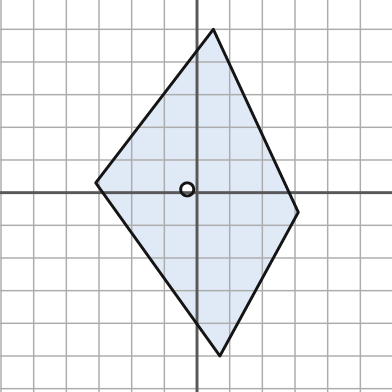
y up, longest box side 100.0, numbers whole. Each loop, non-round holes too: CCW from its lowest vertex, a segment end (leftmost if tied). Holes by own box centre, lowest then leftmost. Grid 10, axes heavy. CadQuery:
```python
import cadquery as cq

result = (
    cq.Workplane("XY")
    .moveTo(7.0, -50.0)
    .lineTo(31.0, -6.0)
    .lineTo(5.0, 50.0)
    .lineTo(-31.0, 3.0)
    .close()
    .moveTo(-3.0, 1.0)
    .circle(2.0)
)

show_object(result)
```